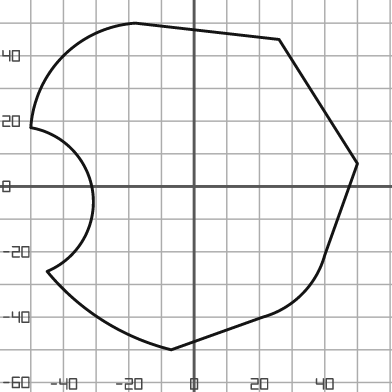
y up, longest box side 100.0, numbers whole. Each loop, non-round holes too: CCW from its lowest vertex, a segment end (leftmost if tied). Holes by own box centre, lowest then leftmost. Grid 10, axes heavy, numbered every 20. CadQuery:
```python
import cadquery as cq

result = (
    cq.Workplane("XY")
    .moveTo(-7.0, -50.0)
    .lineTo(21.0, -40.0)
    .threePointArc((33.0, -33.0), (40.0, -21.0))
    .lineTo(50.0, 7.0)
    .lineTo(26.0, 45.0)
    .lineTo(-18.0, 50.0)
    .threePointArc((-40.0, 40.0), (-50.0, 18.0))
    .threePointArc((-31.0, -2.0), (-45.0, -26.0))
    .threePointArc((-28.0, -41.0), (-7.0, -50.0))
    .close()
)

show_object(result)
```